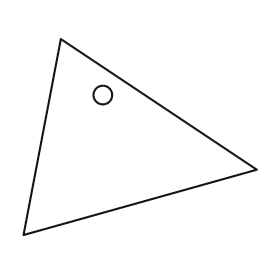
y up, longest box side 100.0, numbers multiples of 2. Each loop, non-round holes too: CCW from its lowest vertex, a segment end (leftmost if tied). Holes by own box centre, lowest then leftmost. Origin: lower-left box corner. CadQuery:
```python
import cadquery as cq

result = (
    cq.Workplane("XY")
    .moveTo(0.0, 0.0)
    .lineTo(100.0, 28.0)
    .lineTo(16.0, 84.0)
    .close()
    .moveTo(34.0, 60.0)
    .circle(4.0)
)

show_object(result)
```